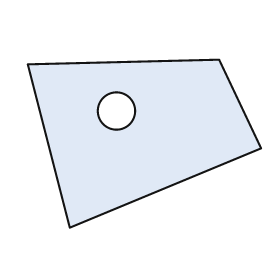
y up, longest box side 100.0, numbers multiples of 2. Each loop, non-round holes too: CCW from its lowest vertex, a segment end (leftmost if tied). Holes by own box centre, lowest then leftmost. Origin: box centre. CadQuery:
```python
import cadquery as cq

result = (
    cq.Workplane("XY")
    .moveTo(-32.0, -36.0)
    .lineTo(50.0, -2.0)
    .lineTo(32.0, 36.0)
    .lineTo(-50.0, 34.0)
    .close()
    .moveTo(-12.0, 14.0)
    .circle(8.0)
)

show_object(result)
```